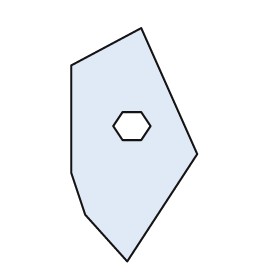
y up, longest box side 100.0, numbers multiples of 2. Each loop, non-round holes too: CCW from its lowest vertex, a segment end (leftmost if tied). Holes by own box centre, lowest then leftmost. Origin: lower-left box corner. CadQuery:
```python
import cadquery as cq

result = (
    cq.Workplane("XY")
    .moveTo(24.0, 0.0)
    .lineTo(54.0, 46.0)
    .lineTo(30.0, 100.0)
    .lineTo(0.0, 84.0)
    .lineTo(0.0, 38.0)
    .lineTo(6.0, 20.0)
    .close()
    .moveTo(22.0, 52.0)
    .lineTo(30.0, 52.0)
    .lineTo(34.0, 58.0)
    .lineTo(30.0, 64.0)
    .lineTo(22.0, 64.0)
    .lineTo(18.0, 58.0)
    .close()
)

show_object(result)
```